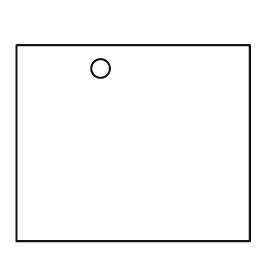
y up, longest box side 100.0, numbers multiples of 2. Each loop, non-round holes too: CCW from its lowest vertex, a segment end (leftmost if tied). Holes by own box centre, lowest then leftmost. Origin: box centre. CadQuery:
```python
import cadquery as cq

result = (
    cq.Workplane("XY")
    .moveTo(-50.0, -42.0)
    .lineTo(50.0, -42.0)
    .lineTo(50.0, 42.0)
    .lineTo(-50.0, 42.0)
    .close()
    .moveTo(-14.0, 32.0)
    .circle(4.0)
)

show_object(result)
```